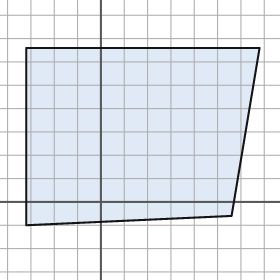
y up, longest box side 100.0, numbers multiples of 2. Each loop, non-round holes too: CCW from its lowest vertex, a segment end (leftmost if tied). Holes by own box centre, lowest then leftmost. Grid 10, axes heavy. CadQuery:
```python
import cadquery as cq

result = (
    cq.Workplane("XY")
    .moveTo(-32.0, -10.0)
    .lineTo(56.0, -6.0)
    .lineTo(68.0, 66.0)
    .lineTo(-32.0, 66.0)
    .close()
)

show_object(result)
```